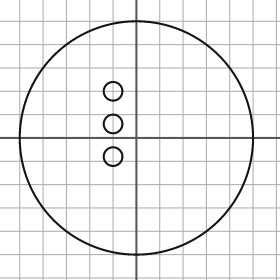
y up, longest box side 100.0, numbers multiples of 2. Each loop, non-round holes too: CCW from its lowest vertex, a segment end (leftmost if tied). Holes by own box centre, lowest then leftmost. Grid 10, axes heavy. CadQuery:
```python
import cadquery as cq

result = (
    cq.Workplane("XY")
    .moveTo(0.0, 0.0)
    .circle(50.0)
    .moveTo(-10.0, -8.0)
    .circle(4.0)
    .moveTo(-10.0, 6.0)
    .circle(4.0)
    .moveTo(-10.0, 20.0)
    .circle(4.0)
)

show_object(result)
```